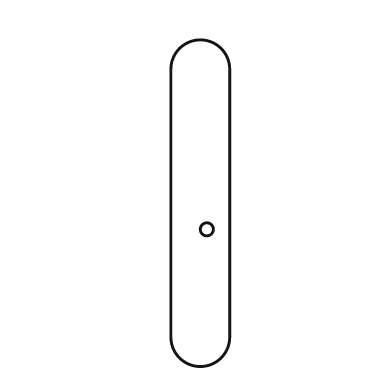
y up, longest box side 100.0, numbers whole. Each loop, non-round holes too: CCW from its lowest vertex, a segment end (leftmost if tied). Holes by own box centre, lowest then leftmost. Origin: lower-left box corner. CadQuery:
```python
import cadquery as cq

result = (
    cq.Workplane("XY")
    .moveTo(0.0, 9.0)
    .threePointArc((9.0, 0.0), (18.0, 9.0))
    .lineTo(18.0, 91.0)
    .threePointArc((9.0, 100.0), (0.0, 91.0))
    .close()
    .moveTo(11.0, 42.0)
    .circle(2.0)
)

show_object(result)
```